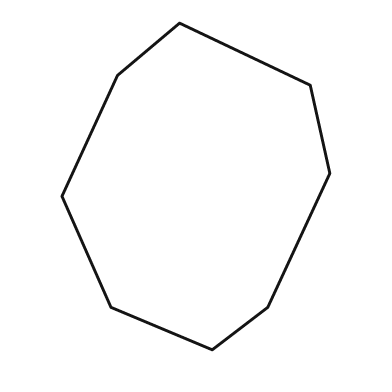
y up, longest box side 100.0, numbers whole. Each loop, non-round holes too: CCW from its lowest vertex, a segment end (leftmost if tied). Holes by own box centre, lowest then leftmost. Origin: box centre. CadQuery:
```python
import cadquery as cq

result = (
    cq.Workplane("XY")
    .moveTo(5.0, -50.0)
    .lineTo(22.0, -37.0)
    .lineTo(41.0, 4.0)
    .lineTo(35.0, 31.0)
    .lineTo(-5.0, 50.0)
    .lineTo(-24.0, 34.0)
    .lineTo(-41.0, -3.0)
    .lineTo(-26.0, -37.0)
    .close()
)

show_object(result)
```